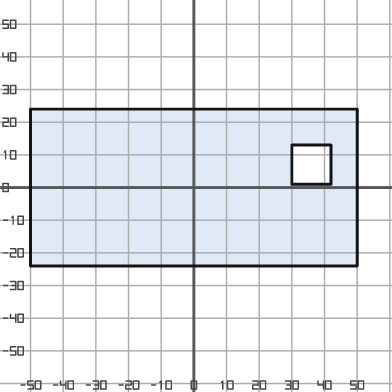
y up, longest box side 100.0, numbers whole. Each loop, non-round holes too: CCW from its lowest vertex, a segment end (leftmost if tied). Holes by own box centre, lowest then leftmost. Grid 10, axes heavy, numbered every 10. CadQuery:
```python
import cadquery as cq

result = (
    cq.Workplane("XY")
    .moveTo(-50.0, -24.0)
    .lineTo(50.0, -24.0)
    .lineTo(50.0, 24.0)
    .lineTo(-50.0, 24.0)
    .close()
    .moveTo(30.0, 1.0)
    .lineTo(42.0, 1.0)
    .lineTo(42.0, 13.0)
    .lineTo(30.0, 13.0)
    .close()
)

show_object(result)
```